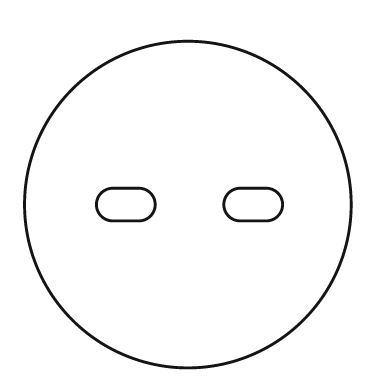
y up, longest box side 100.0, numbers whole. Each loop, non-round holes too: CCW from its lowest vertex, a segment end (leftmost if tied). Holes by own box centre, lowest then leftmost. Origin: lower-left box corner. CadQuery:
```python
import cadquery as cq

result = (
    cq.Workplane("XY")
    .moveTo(50.0, 50.0)
    .circle(50.0)
    .moveTo(27.0, 45.0)
    .lineTo(35.0, 45.0)
    .threePointArc((40.0, 50.0), (35.0, 55.0))
    .lineTo(27.0, 55.0)
    .threePointArc((22.0, 50.0), (27.0, 45.0))
    .close()
    .moveTo(66.0, 45.0)
    .lineTo(74.0, 45.0)
    .threePointArc((79.0, 50.0), (74.0, 55.0))
    .lineTo(66.0, 55.0)
    .threePointArc((61.0, 50.0), (66.0, 45.0))
    .close()
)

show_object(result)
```